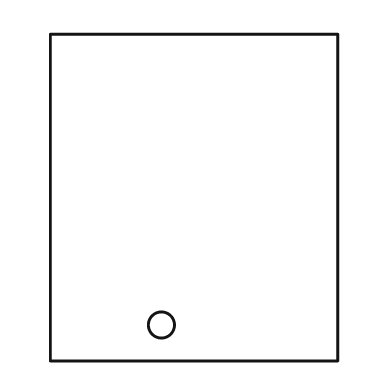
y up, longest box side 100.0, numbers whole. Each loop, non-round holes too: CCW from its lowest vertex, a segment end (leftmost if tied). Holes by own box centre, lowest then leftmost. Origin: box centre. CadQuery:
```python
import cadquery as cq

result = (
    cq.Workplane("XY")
    .moveTo(-44.0, -50.0)
    .lineTo(44.0, -50.0)
    .lineTo(44.0, 50.0)
    .lineTo(-44.0, 50.0)
    .close()
    .moveTo(-10.0, -39.0)
    .circle(4.0)
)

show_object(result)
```